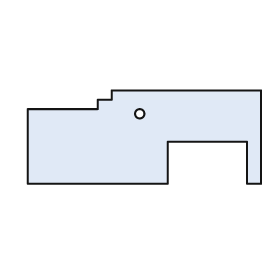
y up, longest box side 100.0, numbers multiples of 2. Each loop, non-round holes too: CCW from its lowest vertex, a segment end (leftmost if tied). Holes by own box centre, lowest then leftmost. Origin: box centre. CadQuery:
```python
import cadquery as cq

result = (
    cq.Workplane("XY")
    .moveTo(-50.0, -20.0)
    .lineTo(10.0, -20.0)
    .lineTo(10.0, -2.0)
    .lineTo(44.0, -2.0)
    .lineTo(44.0, -20.0)
    .lineTo(50.0, -20.0)
    .lineTo(50.0, 20.0)
    .lineTo(-14.0, 20.0)
    .lineTo(-14.0, 16.0)
    .lineTo(-20.0, 16.0)
    .lineTo(-20.0, 12.0)
    .lineTo(-50.0, 12.0)
    .close()
    .moveTo(-2.0, 10.0)
    .circle(2.0)
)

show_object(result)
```